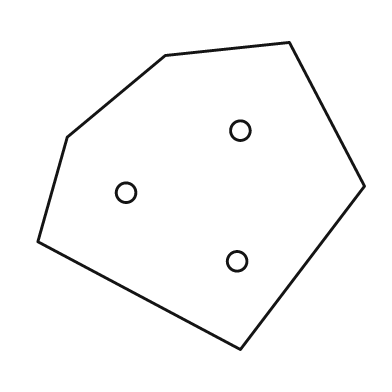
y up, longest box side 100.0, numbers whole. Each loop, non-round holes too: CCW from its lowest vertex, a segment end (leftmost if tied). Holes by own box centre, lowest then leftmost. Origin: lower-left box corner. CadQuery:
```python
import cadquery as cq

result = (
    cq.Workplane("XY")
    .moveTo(62.0, 0.0)
    .lineTo(100.0, 50.0)
    .lineTo(77.0, 94.0)
    .lineTo(39.0, 90.0)
    .lineTo(9.0, 65.0)
    .lineTo(0.0, 33.0)
    .close()
    .moveTo(61.0, 27.0)
    .circle(3.0)
    .moveTo(27.0, 48.0)
    .circle(3.0)
    .moveTo(62.0, 67.0)
    .circle(3.0)
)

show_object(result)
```